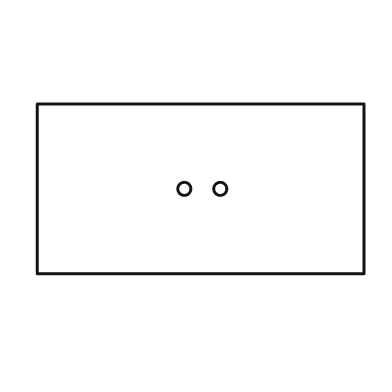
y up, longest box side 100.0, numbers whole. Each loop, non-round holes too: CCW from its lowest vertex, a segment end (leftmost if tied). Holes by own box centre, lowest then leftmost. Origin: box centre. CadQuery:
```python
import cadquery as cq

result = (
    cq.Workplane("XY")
    .moveTo(-50.0, -26.0)
    .lineTo(50.0, -26.0)
    .lineTo(50.0, 26.0)
    .lineTo(-50.0, 26.0)
    .close()
    .moveTo(-5.0, 0.0)
    .circle(2.0)
    .moveTo(6.0, 0.0)
    .circle(2.0)
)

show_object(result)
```